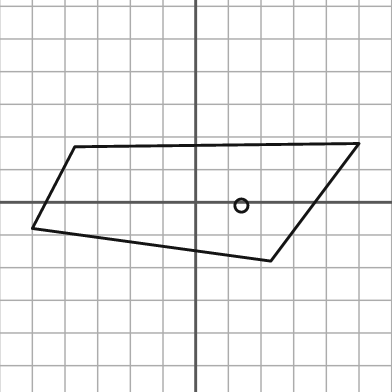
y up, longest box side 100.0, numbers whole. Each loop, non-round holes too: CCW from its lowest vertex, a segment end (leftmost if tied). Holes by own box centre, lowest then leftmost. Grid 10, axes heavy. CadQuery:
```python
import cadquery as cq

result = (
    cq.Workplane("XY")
    .moveTo(23.0, -18.0)
    .lineTo(50.0, 18.0)
    .lineTo(-37.0, 17.0)
    .lineTo(-50.0, -8.0)
    .close()
    .moveTo(14.0, -1.0)
    .circle(2.0)
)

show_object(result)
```